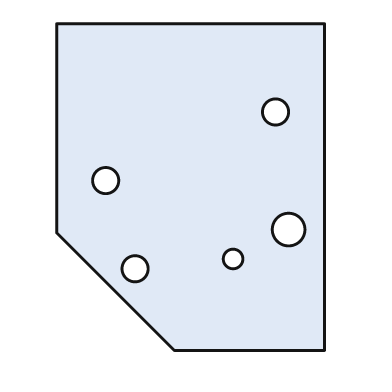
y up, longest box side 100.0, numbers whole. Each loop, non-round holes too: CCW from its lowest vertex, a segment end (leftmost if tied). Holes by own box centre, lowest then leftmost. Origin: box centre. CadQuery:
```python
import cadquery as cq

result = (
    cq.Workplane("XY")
    .moveTo(-5.0, -50.0)
    .lineTo(41.0, -50.0)
    .lineTo(41.0, 50.0)
    .lineTo(-41.0, 50.0)
    .lineTo(-41.0, -14.0)
    .close()
    .moveTo(-17.0, -25.0)
    .circle(4.0)
    .moveTo(13.0, -22.0)
    .circle(3.0)
    .moveTo(30.0, -13.0)
    .circle(5.0)
    .moveTo(-26.0, 2.0)
    .circle(4.0)
    .moveTo(26.0, 23.0)
    .circle(4.0)
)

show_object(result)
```